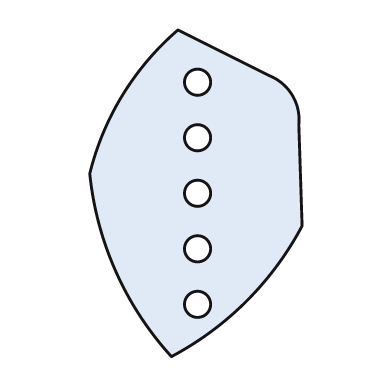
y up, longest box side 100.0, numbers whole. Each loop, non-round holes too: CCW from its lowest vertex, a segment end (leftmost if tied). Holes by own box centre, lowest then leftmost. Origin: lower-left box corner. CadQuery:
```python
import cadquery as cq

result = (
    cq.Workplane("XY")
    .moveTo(25.0, 0.0)
    .threePointArc((48.0, 17.0), (65.0, 40.0))
    .lineTo(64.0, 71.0)
    .threePointArc((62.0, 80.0), (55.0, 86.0))
    .lineTo(27.0, 100.0)
    .threePointArc((10.0, 80.0), (0.0, 56.0))
    .threePointArc((8.0, 26.0), (25.0, 0.0))
    .close()
    .moveTo(33.0, 16.0)
    .circle(4.0)
    .moveTo(33.0, 33.0)
    .circle(4.0)
    .moveTo(33.0, 50.0)
    .circle(4.0)
    .moveTo(33.0, 67.0)
    .circle(4.0)
    .moveTo(33.0, 84.0)
    .circle(4.0)
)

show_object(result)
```